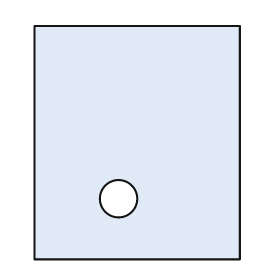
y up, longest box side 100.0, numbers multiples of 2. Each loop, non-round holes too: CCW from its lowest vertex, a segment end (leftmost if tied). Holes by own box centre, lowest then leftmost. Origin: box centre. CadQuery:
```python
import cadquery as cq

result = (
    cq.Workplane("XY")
    .moveTo(-44.0, -50.0)
    .lineTo(44.0, -50.0)
    .lineTo(44.0, 50.0)
    .lineTo(-44.0, 50.0)
    .close()
    .moveTo(-8.0, -24.0)
    .circle(8.0)
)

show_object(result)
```